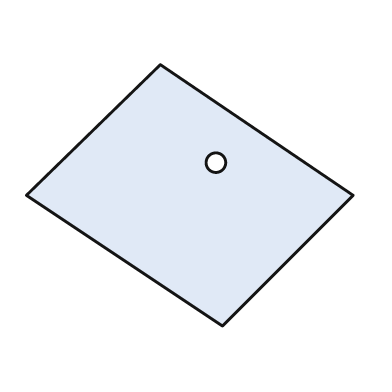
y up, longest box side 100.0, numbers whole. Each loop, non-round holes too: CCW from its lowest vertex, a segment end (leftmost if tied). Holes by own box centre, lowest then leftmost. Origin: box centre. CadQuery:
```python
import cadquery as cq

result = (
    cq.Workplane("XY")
    .moveTo(10.0, -40.0)
    .lineTo(50.0, 0.0)
    .lineTo(-9.0, 40.0)
    .lineTo(-50.0, 0.0)
    .close()
    .moveTo(8.0, 10.0)
    .circle(3.0)
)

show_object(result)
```